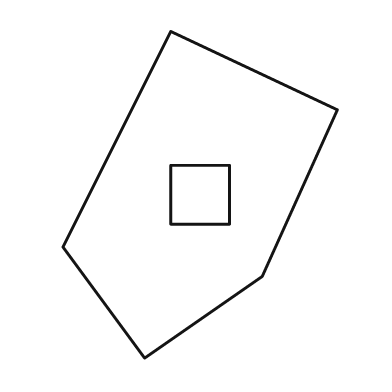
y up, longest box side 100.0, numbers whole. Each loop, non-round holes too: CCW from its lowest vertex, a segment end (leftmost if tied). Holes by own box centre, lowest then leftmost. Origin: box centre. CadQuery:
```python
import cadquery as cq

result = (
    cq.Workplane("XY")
    .moveTo(-17.0, -50.0)
    .lineTo(19.0, -25.0)
    .lineTo(42.0, 26.0)
    .lineTo(-9.0, 50.0)
    .lineTo(-42.0, -16.0)
    .close()
    .moveTo(-9.0, -9.0)
    .lineTo(9.0, -9.0)
    .lineTo(9.0, 9.0)
    .lineTo(-9.0, 9.0)
    .close()
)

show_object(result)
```